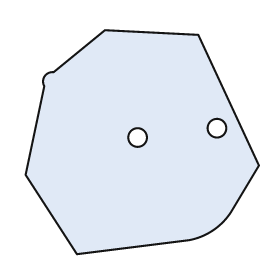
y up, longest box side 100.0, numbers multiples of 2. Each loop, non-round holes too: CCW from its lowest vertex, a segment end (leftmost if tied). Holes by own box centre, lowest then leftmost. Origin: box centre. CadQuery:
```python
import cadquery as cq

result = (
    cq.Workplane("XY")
    .moveTo(-28.0, -48.0)
    .lineTo(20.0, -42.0)
    .threePointArc((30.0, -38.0), (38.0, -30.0))
    .lineTo(50.0, -10.0)
    .lineTo(24.0, 46.0)
    .lineTo(-16.0, 48.0)
    .lineTo(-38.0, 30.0)
    .threePointArc((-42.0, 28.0), (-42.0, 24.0))
    .lineTo(-50.0, -14.0)
    .close()
    .moveTo(-2.0, 2.0)
    .circle(4.0)
    .moveTo(32.0, 6.0)
    .circle(4.0)
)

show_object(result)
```